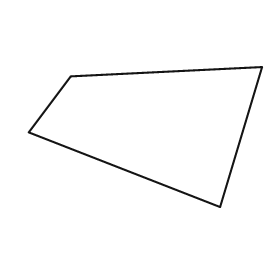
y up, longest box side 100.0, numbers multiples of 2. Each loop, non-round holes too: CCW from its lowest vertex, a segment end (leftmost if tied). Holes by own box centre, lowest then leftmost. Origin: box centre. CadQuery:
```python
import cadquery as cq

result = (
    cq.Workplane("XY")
    .moveTo(32.0, -30.0)
    .lineTo(50.0, 30.0)
    .lineTo(-32.0, 26.0)
    .lineTo(-50.0, 2.0)
    .close()
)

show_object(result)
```